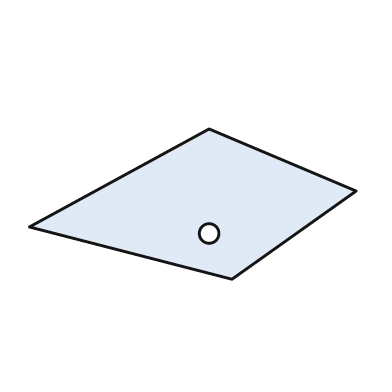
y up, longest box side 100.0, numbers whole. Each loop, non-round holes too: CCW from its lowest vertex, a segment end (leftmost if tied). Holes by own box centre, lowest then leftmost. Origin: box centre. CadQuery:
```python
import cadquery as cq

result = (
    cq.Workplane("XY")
    .moveTo(12.0, -23.0)
    .lineTo(50.0, 4.0)
    .lineTo(5.0, 23.0)
    .lineTo(-50.0, -7.0)
    .close()
    .moveTo(5.0, -9.0)
    .circle(3.0)
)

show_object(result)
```